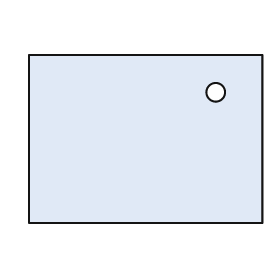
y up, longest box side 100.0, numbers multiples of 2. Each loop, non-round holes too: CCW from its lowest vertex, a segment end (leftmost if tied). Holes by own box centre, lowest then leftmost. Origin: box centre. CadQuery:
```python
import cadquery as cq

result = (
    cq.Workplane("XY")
    .moveTo(-50.0, -36.0)
    .lineTo(50.0, -36.0)
    .lineTo(50.0, 36.0)
    .lineTo(-50.0, 36.0)
    .close()
    .moveTo(30.0, 20.0)
    .circle(4.0)
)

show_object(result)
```